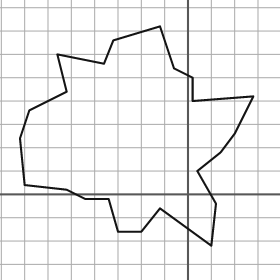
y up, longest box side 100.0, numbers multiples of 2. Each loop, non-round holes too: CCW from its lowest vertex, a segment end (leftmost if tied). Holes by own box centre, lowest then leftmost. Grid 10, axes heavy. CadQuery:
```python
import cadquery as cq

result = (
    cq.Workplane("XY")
    .moveTo(10.0, -22.0)
    .lineTo(12.0, -4.0)
    .lineTo(4.0, 10.0)
    .lineTo(14.0, 18.0)
    .lineTo(20.0, 26.0)
    .lineTo(28.0, 42.0)
    .lineTo(2.0, 40.0)
    .lineTo(2.0, 50.0)
    .lineTo(-6.0, 54.0)
    .lineTo(-12.0, 72.0)
    .lineTo(-32.0, 66.0)
    .lineTo(-36.0, 56.0)
    .lineTo(-56.0, 60.0)
    .lineTo(-52.0, 44.0)
    .lineTo(-68.0, 36.0)
    .lineTo(-72.0, 24.0)
    .lineTo(-70.0, 4.0)
    .lineTo(-52.0, 2.0)
    .lineTo(-44.0, -2.0)
    .lineTo(-34.0, -2.0)
    .lineTo(-30.0, -16.0)
    .lineTo(-20.0, -16.0)
    .lineTo(-12.0, -6.0)
    .close()
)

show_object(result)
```